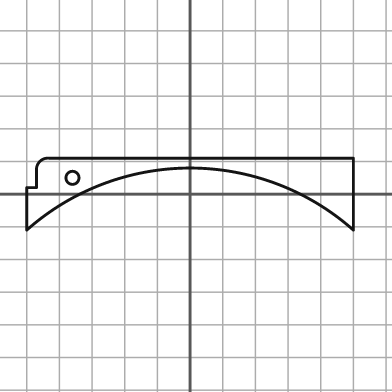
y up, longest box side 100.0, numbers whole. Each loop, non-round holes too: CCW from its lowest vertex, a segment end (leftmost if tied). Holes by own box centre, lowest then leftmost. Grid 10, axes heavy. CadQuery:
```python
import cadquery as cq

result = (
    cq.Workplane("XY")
    .moveTo(-50.0, -11.0)
    .threePointArc((0.0, 8.0), (50.0, -11.0))
    .lineTo(50.0, 11.0)
    .lineTo(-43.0, 11.0)
    .threePointArc((-46.0, 10.0), (-47.0, 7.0))
    .lineTo(-47.0, 2.0)
    .lineTo(-50.0, 2.0)
    .close()
    .moveTo(-36.0, 5.0)
    .circle(2.0)
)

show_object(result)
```